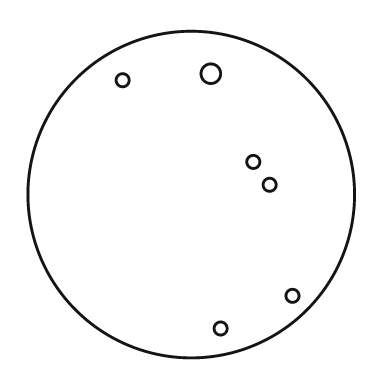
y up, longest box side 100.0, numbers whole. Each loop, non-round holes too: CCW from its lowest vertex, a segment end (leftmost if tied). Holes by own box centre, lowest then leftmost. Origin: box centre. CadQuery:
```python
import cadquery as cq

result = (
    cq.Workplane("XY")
    .moveTo(0.0, 0.0)
    .circle(50.0)
    .moveTo(9.0, -41.0)
    .circle(2.0)
    .moveTo(31.0, -31.0)
    .circle(2.0)
    .moveTo(24.0, 3.0)
    .circle(2.0)
    .moveTo(19.0, 10.0)
    .circle(2.0)
    .moveTo(-21.0, 35.0)
    .circle(2.0)
    .moveTo(6.0, 37.0)
    .circle(3.0)
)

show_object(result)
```